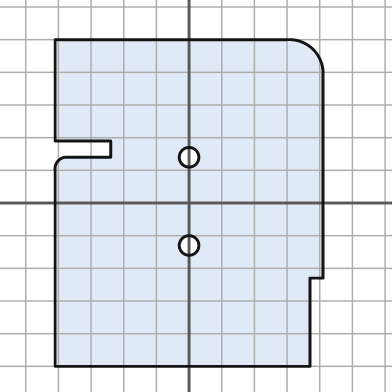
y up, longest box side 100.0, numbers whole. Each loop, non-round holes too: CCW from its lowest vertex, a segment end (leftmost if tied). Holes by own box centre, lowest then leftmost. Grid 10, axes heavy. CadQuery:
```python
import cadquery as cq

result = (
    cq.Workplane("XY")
    .moveTo(-41.0, -50.0)
    .lineTo(37.0, -50.0)
    .lineTo(37.0, -23.0)
    .lineTo(41.0, -23.0)
    .lineTo(41.0, 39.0)
    .threePointArc((38.0, 47.0), (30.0, 50.0))
    .lineTo(-41.0, 50.0)
    .lineTo(-41.0, 19.0)
    .lineTo(-24.0, 19.0)
    .lineTo(-24.0, 14.0)
    .lineTo(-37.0, 14.0)
    .threePointArc((-40.0, 13.0), (-41.0, 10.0))
    .close()
    .moveTo(0.0, -13.0)
    .circle(3.0)
    .moveTo(0.0, 14.0)
    .circle(3.0)
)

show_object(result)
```